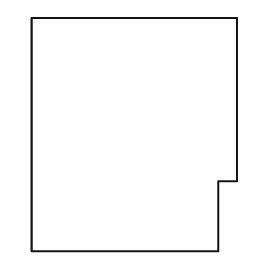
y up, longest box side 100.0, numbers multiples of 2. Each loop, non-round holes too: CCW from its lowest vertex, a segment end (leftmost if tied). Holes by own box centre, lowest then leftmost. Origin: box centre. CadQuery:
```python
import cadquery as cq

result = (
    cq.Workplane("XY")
    .moveTo(-44.0, -50.0)
    .lineTo(36.0, -50.0)
    .lineTo(36.0, -20.0)
    .lineTo(44.0, -20.0)
    .lineTo(44.0, 50.0)
    .lineTo(-44.0, 50.0)
    .close()
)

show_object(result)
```